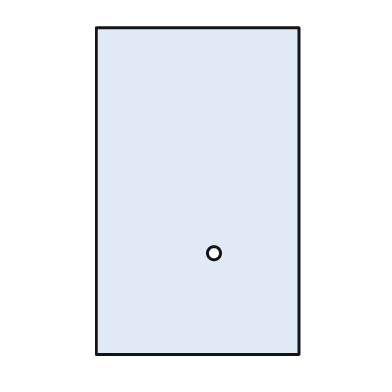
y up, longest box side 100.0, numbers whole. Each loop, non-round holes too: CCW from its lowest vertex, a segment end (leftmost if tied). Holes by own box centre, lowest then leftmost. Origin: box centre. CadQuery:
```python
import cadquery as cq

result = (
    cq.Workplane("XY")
    .moveTo(-31.0, -50.0)
    .lineTo(31.0, -50.0)
    .lineTo(31.0, 50.0)
    .lineTo(-31.0, 50.0)
    .close()
    .moveTo(5.0, -19.0)
    .circle(2.0)
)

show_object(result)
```